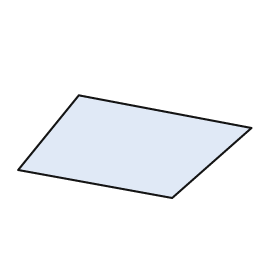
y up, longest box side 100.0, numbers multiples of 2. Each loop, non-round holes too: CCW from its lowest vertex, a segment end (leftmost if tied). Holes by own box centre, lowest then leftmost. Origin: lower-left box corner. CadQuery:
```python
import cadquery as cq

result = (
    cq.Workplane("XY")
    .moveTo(66.0, 0.0)
    .lineTo(100.0, 30.0)
    .lineTo(26.0, 44.0)
    .lineTo(0.0, 12.0)
    .close()
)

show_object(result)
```